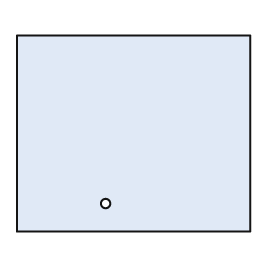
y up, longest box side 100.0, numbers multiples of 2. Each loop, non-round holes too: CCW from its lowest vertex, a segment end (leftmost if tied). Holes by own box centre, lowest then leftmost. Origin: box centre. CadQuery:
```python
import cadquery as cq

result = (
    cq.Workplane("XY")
    .moveTo(-50.0, -42.0)
    .lineTo(50.0, -42.0)
    .lineTo(50.0, 42.0)
    .lineTo(-50.0, 42.0)
    .close()
    .moveTo(-12.0, -30.0)
    .circle(2.0)
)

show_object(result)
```